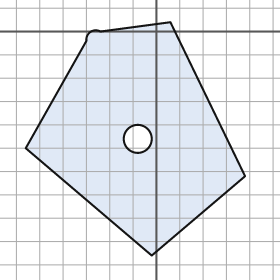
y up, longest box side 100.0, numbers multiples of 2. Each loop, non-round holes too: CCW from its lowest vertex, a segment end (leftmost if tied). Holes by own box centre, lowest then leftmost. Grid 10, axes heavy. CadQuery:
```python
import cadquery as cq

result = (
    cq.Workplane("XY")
    .moveTo(-2.0, -96.0)
    .lineTo(38.0, -62.0)
    .lineTo(6.0, 4.0)
    .lineTo(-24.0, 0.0)
    .threePointArc((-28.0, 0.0), (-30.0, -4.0))
    .lineTo(-56.0, -50.0)
    .close()
    .moveTo(-8.0, -46.0)
    .circle(6.0)
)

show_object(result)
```